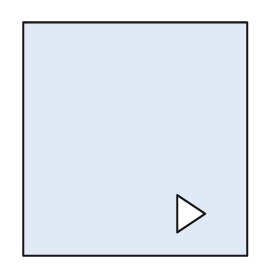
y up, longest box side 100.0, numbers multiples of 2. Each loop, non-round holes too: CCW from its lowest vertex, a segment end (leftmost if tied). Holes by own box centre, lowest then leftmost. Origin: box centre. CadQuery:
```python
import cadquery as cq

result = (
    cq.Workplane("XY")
    .moveTo(-48.0, -50.0)
    .lineTo(48.0, -50.0)
    .lineTo(48.0, 50.0)
    .lineTo(-48.0, 50.0)
    .close()
    .moveTo(18.0, -40.0)
    .lineTo(30.0, -32.0)
    .lineTo(18.0, -24.0)
    .close()
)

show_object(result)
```